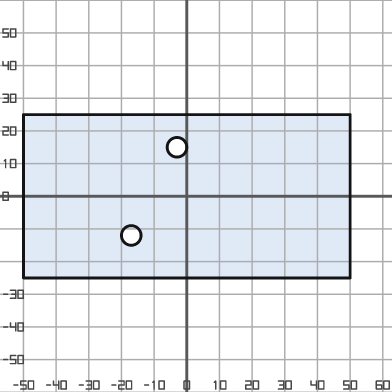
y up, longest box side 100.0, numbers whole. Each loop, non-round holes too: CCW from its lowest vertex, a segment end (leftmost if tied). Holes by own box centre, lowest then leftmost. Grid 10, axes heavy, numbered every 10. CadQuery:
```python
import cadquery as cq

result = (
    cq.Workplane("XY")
    .moveTo(-50.0, -25.0)
    .lineTo(50.0, -25.0)
    .lineTo(50.0, 25.0)
    .lineTo(-50.0, 25.0)
    .close()
    .moveTo(-17.0, -12.0)
    .circle(3.0)
    .moveTo(-3.0, 15.0)
    .circle(3.0)
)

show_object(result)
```